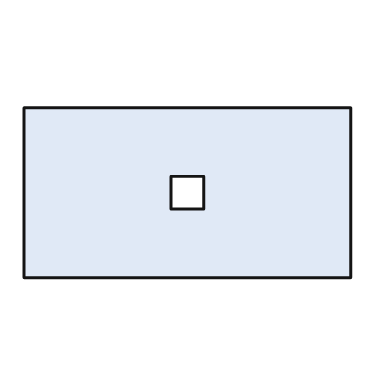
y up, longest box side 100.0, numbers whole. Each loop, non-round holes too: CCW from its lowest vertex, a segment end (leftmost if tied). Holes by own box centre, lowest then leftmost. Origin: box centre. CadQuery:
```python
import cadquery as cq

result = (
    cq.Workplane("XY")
    .moveTo(-50.0, -26.0)
    .lineTo(50.0, -26.0)
    .lineTo(50.0, 26.0)
    .lineTo(-50.0, 26.0)
    .close()
    .moveTo(-5.0, -5.0)
    .lineTo(5.0, -5.0)
    .lineTo(5.0, 5.0)
    .lineTo(-5.0, 5.0)
    .close()
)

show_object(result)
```